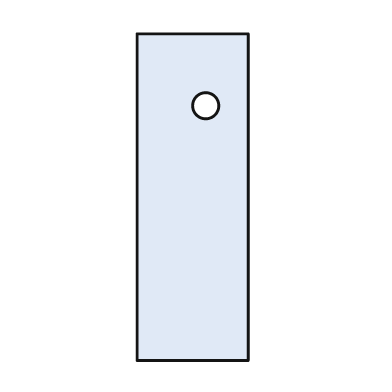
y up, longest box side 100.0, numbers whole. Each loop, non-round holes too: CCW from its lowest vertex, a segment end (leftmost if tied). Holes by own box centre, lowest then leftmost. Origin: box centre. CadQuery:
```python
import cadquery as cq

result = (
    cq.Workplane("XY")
    .moveTo(-17.0, -50.0)
    .lineTo(17.0, -50.0)
    .lineTo(17.0, 50.0)
    .lineTo(-17.0, 50.0)
    .close()
    .moveTo(4.0, 28.0)
    .circle(4.0)
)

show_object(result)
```